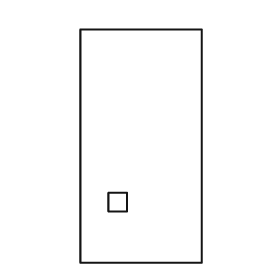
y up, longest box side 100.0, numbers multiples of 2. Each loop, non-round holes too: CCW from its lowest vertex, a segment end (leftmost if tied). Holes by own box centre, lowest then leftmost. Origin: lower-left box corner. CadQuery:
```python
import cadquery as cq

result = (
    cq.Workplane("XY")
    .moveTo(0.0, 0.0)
    .lineTo(52.0, 0.0)
    .lineTo(52.0, 100.0)
    .lineTo(0.0, 100.0)
    .close()
    .moveTo(12.0, 22.0)
    .lineTo(20.0, 22.0)
    .lineTo(20.0, 30.0)
    .lineTo(12.0, 30.0)
    .close()
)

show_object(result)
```